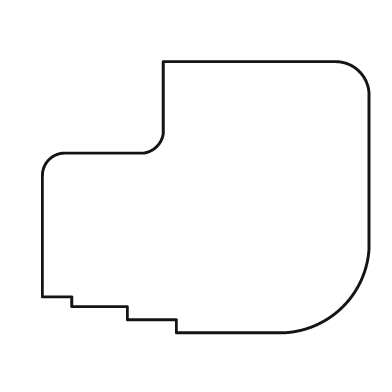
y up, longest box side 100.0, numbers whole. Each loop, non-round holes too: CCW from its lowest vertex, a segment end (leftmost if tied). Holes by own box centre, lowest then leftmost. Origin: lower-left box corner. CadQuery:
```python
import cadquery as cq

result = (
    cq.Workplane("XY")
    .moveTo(41.0, 0.0)
    .lineTo(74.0, 0.0)
    .threePointArc((92.0, 8.0), (100.0, 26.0))
    .lineTo(100.0, 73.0)
    .threePointArc((97.0, 80.0), (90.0, 83.0))
    .lineTo(37.0, 83.0)
    .lineTo(37.0, 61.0)
    .threePointArc((35.0, 57.0), (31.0, 55.0))
    .lineTo(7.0, 55.0)
    .threePointArc((2.0, 53.0), (0.0, 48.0))
    .lineTo(0.0, 11.0)
    .lineTo(9.0, 11.0)
    .lineTo(9.0, 8.0)
    .lineTo(26.0, 8.0)
    .lineTo(26.0, 4.0)
    .lineTo(41.0, 4.0)
    .close()
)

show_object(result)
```